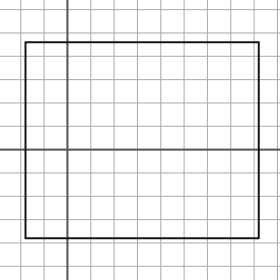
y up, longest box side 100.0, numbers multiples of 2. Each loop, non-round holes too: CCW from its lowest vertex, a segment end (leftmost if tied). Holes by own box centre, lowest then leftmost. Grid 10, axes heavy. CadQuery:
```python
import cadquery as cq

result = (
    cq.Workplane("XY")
    .moveTo(-18.0, -38.0)
    .lineTo(82.0, -38.0)
    .lineTo(82.0, 46.0)
    .lineTo(-18.0, 46.0)
    .close()
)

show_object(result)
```